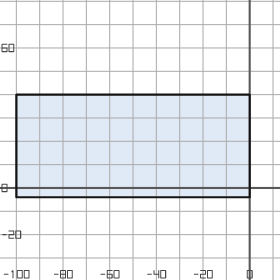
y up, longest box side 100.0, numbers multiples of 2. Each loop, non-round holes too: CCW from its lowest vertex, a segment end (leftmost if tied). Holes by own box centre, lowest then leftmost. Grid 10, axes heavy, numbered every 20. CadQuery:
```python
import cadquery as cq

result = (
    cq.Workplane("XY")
    .moveTo(-100.0, -4.0)
    .lineTo(0.0, -4.0)
    .lineTo(0.0, 40.0)
    .lineTo(-100.0, 40.0)
    .close()
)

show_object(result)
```